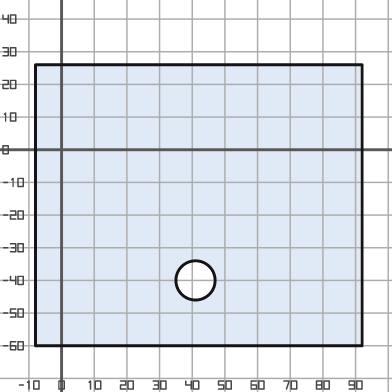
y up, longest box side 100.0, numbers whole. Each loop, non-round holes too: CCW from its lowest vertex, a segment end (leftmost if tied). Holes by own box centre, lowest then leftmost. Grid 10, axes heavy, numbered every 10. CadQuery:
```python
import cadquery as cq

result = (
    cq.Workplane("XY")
    .moveTo(-8.0, -60.0)
    .lineTo(92.0, -60.0)
    .lineTo(92.0, 26.0)
    .lineTo(-8.0, 26.0)
    .close()
    .moveTo(41.0, -40.0)
    .circle(6.0)
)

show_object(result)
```